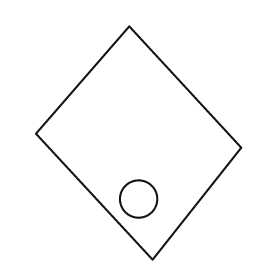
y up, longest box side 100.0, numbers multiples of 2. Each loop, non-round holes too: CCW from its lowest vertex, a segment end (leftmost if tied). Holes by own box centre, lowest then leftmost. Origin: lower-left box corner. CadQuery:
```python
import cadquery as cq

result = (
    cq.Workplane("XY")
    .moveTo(50.0, 0.0)
    .lineTo(88.0, 48.0)
    .lineTo(40.0, 100.0)
    .lineTo(0.0, 54.0)
    .close()
    .moveTo(44.0, 26.0)
    .circle(8.0)
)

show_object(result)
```